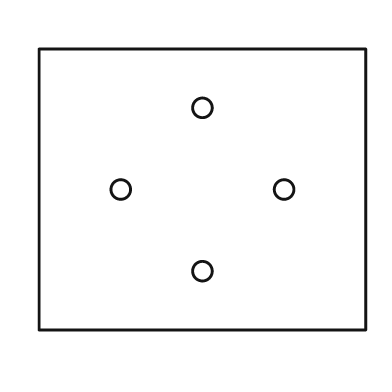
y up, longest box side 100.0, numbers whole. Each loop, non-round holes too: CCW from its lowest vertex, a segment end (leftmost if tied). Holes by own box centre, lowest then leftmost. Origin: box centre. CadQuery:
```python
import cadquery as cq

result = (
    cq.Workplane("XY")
    .moveTo(-50.0, -43.0)
    .lineTo(50.0, -43.0)
    .lineTo(50.0, 43.0)
    .lineTo(-50.0, 43.0)
    .close()
    .moveTo(0.0, -25.0)
    .circle(3.0)
    .moveTo(-25.0, 0.0)
    .circle(3.0)
    .moveTo(25.0, 0.0)
    .circle(3.0)
    .moveTo(0.0, 25.0)
    .circle(3.0)
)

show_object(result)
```